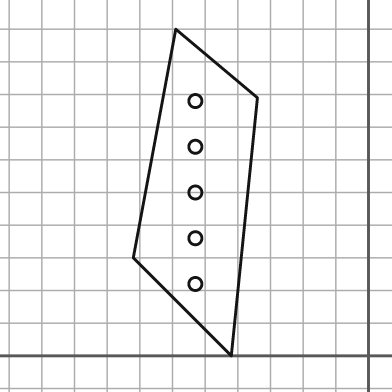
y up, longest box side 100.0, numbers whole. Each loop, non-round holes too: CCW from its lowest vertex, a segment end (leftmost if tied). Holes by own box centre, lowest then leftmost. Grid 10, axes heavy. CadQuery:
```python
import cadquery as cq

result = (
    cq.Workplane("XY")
    .moveTo(-42.0, 0.0)
    .lineTo(-34.0, 79.0)
    .lineTo(-59.0, 100.0)
    .lineTo(-72.0, 30.0)
    .close()
    .moveTo(-53.0, 22.0)
    .circle(2.0)
    .moveTo(-53.0, 36.0)
    .circle(2.0)
    .moveTo(-53.0, 50.0)
    .circle(2.0)
    .moveTo(-53.0, 64.0)
    .circle(2.0)
    .moveTo(-53.0, 78.0)
    .circle(2.0)
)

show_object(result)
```